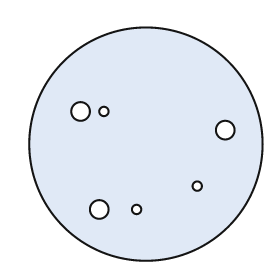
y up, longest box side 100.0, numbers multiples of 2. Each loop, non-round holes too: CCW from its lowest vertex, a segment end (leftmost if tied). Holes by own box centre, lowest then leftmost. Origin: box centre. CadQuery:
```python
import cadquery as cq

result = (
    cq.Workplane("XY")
    .moveTo(0.0, 0.0)
    .circle(50.0)
    .moveTo(-20.0, -28.0)
    .circle(4.0)
    .moveTo(-4.0, -28.0)
    .circle(2.0)
    .moveTo(22.0, -18.0)
    .circle(2.0)
    .moveTo(34.0, 6.0)
    .circle(4.0)
    .moveTo(-28.0, 14.0)
    .circle(4.0)
    .moveTo(-18.0, 14.0)
    .circle(2.0)
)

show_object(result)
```